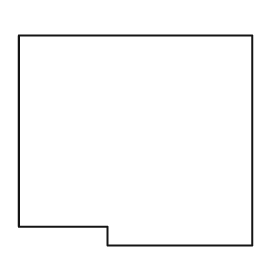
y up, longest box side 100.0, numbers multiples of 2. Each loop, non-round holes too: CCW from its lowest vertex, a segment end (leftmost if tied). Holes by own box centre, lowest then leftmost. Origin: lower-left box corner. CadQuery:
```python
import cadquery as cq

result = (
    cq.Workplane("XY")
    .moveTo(38.0, 0.0)
    .lineTo(100.0, 0.0)
    .lineTo(100.0, 90.0)
    .lineTo(0.0, 90.0)
    .lineTo(0.0, 8.0)
    .lineTo(38.0, 8.0)
    .close()
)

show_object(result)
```